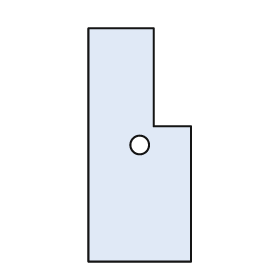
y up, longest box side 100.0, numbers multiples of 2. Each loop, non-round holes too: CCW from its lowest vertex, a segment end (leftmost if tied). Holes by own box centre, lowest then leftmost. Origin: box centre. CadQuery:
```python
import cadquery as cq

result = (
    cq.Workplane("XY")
    .moveTo(-22.0, -50.0)
    .lineTo(22.0, -50.0)
    .lineTo(22.0, 8.0)
    .lineTo(6.0, 8.0)
    .lineTo(6.0, 50.0)
    .lineTo(-22.0, 50.0)
    .close()
    .moveTo(0.0, 0.0)
    .circle(4.0)
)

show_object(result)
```